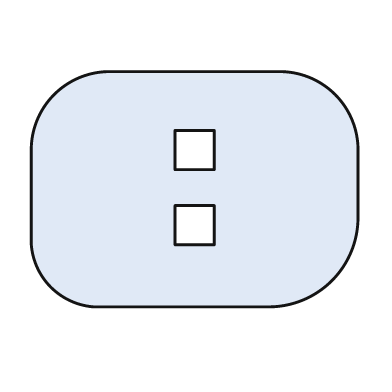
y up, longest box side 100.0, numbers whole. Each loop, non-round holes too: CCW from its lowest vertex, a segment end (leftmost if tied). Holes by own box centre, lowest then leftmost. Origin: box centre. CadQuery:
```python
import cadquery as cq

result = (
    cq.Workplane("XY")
    .moveTo(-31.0, -36.0)
    .lineTo(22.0, -36.0)
    .threePointArc((42.0, -28.0), (50.0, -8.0))
    .lineTo(50.0, 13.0)
    .threePointArc((43.0, 29.0), (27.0, 36.0))
    .lineTo(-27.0, 36.0)
    .threePointArc((-43.0, 29.0), (-50.0, 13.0))
    .lineTo(-50.0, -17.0)
    .threePointArc((-44.0, -30.0), (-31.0, -36.0))
    .close()
    .moveTo(-6.0, -17.0)
    .lineTo(6.0, -17.0)
    .lineTo(6.0, -5.0)
    .lineTo(-6.0, -5.0)
    .close()
    .moveTo(-6.0, 6.0)
    .lineTo(6.0, 6.0)
    .lineTo(6.0, 18.0)
    .lineTo(-6.0, 18.0)
    .close()
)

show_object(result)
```